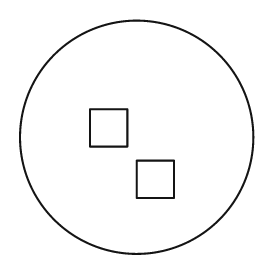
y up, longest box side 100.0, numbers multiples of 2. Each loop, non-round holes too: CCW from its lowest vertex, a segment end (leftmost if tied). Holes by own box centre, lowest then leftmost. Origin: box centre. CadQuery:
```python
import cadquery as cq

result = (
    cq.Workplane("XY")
    .moveTo(0.0, 0.0)
    .circle(50.0)
    .moveTo(0.0, -26.0)
    .lineTo(16.0, -26.0)
    .lineTo(16.0, -10.0)
    .lineTo(0.0, -10.0)
    .close()
    .moveTo(-20.0, -4.0)
    .lineTo(-4.0, -4.0)
    .lineTo(-4.0, 12.0)
    .lineTo(-20.0, 12.0)
    .close()
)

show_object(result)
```